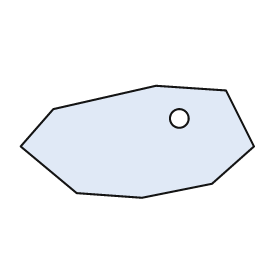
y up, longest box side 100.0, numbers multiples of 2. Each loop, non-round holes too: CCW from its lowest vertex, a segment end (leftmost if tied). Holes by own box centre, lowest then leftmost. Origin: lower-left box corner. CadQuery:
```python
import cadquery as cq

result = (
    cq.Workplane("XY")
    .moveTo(52.0, 0.0)
    .lineTo(82.0, 6.0)
    .lineTo(100.0, 22.0)
    .lineTo(88.0, 46.0)
    .lineTo(58.0, 48.0)
    .lineTo(14.0, 38.0)
    .lineTo(0.0, 22.0)
    .lineTo(24.0, 2.0)
    .close()
    .moveTo(68.0, 34.0)
    .circle(4.0)
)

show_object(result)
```